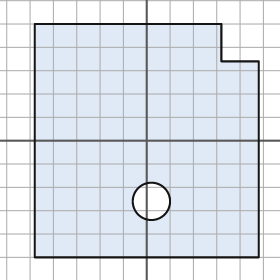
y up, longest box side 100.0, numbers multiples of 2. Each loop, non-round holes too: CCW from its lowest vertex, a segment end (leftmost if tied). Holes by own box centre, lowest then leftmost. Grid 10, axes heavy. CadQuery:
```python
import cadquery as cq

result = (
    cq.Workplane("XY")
    .moveTo(-48.0, -50.0)
    .lineTo(48.0, -50.0)
    .lineTo(48.0, 34.0)
    .lineTo(32.0, 34.0)
    .lineTo(32.0, 50.0)
    .lineTo(-48.0, 50.0)
    .close()
    .moveTo(2.0, -26.0)
    .circle(8.0)
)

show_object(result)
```